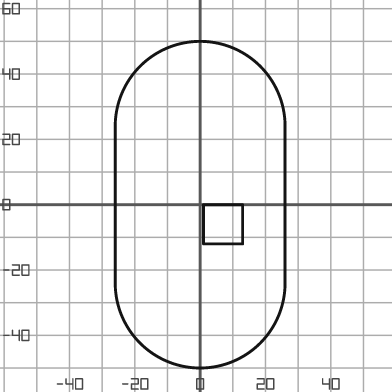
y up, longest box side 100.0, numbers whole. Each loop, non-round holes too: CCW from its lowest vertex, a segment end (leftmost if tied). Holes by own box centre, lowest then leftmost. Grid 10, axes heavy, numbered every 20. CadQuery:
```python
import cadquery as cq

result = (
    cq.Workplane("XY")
    .moveTo(-26.0, -24.0)
    .threePointArc((0.0, -50.0), (26.0, -24.0))
    .lineTo(26.0, 24.0)
    .threePointArc((0.0, 50.0), (-26.0, 24.0))
    .close()
    .moveTo(1.0, -12.0)
    .lineTo(13.0, -12.0)
    .lineTo(13.0, 0.0)
    .lineTo(1.0, 0.0)
    .close()
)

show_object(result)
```